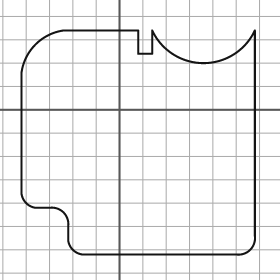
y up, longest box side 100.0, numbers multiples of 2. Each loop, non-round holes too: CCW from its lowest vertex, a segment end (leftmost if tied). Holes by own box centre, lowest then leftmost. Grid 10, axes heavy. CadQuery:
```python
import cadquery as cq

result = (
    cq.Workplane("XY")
    .moveTo(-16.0, -62.0)
    .lineTo(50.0, -62.0)
    .threePointArc((56.0, -60.0), (58.0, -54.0))
    .lineTo(58.0, 34.0)
    .threePointArc((36.0, 20.0), (14.0, 34.0))
    .lineTo(14.0, 24.0)
    .lineTo(8.0, 24.0)
    .lineTo(8.0, 34.0)
    .lineTo(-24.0, 34.0)
    .threePointArc((-36.0, 28.0), (-42.0, 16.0))
    .lineTo(-42.0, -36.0)
    .threePointArc((-40.0, -40.0), (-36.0, -42.0))
    .lineTo(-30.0, -42.0)
    .threePointArc((-24.0, -44.0), (-22.0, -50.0))
    .lineTo(-22.0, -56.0)
    .threePointArc((-20.0, -60.0), (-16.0, -62.0))
    .close()
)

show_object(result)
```